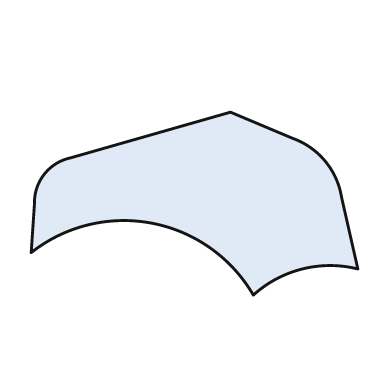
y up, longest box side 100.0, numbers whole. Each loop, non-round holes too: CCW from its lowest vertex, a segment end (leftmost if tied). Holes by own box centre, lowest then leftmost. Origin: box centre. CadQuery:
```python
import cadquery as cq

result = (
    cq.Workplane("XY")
    .moveTo(18.0, -28.0)
    .threePointArc((33.0, -20.0), (50.0, -20.0))
    .lineTo(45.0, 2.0)
    .threePointArc((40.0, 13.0), (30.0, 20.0))
    .lineTo(11.0, 28.0)
    .lineTo(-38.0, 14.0)
    .threePointArc((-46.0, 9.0), (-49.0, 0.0))
    .lineTo(-50.0, -15.0)
    .threePointArc((-13.0, -6.0), (18.0, -28.0))
    .close()
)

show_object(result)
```